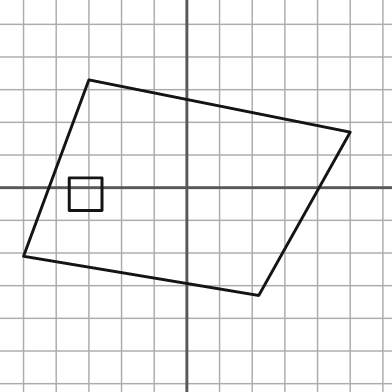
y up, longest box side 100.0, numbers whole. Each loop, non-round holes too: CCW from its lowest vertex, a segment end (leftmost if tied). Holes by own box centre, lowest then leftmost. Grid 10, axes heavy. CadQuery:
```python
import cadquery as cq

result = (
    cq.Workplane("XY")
    .moveTo(22.0, -33.0)
    .lineTo(50.0, 17.0)
    .lineTo(-30.0, 33.0)
    .lineTo(-50.0, -21.0)
    .close()
    .moveTo(-36.0, -7.0)
    .lineTo(-26.0, -7.0)
    .lineTo(-26.0, 3.0)
    .lineTo(-36.0, 3.0)
    .close()
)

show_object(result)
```